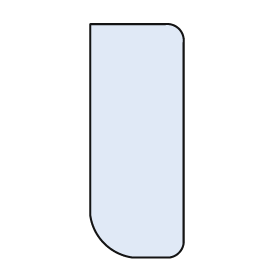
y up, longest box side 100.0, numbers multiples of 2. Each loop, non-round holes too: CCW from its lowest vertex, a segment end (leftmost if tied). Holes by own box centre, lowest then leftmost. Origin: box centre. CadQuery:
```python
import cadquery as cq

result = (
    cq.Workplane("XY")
    .moveTo(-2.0, -50.0)
    .lineTo(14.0, -50.0)
    .threePointArc((18.0, -48.0), (20.0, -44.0))
    .lineTo(20.0, 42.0)
    .threePointArc((18.0, 48.0), (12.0, 50.0))
    .lineTo(-20.0, 50.0)
    .lineTo(-20.0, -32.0)
    .threePointArc((-14.0, -44.0), (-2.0, -50.0))
    .close()
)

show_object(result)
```